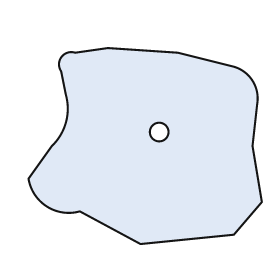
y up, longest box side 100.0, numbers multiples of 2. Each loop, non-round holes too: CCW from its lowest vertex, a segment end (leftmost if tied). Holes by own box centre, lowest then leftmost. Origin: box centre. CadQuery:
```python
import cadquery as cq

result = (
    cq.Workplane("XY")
    .moveTo(-2.0, -42.0)
    .lineTo(38.0, -38.0)
    .lineTo(50.0, -24.0)
    .lineTo(46.0, 0.0)
    .lineTo(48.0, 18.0)
    .threePointArc((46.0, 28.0), (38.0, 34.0))
    .lineTo(14.0, 40.0)
    .lineTo(-16.0, 42.0)
    .lineTo(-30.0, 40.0)
    .threePointArc((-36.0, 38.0), (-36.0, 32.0))
    .lineTo(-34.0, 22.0)
    .threePointArc((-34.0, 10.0), (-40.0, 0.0))
    .lineTo(-50.0, -14.0)
    .threePointArc((-42.0, -26.0), (-28.0, -28.0))
    .close()
    .moveTo(6.0, 6.0)
    .circle(4.0)
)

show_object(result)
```